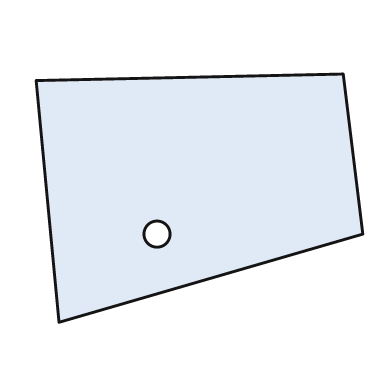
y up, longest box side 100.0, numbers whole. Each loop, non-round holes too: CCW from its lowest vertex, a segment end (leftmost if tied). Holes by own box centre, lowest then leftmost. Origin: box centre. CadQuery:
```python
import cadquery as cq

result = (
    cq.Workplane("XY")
    .moveTo(-43.0, -38.0)
    .lineTo(50.0, -11.0)
    .lineTo(44.0, 38.0)
    .lineTo(-50.0, 36.0)
    .close()
    .moveTo(-13.0, -11.0)
    .circle(4.0)
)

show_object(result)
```